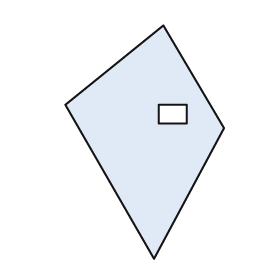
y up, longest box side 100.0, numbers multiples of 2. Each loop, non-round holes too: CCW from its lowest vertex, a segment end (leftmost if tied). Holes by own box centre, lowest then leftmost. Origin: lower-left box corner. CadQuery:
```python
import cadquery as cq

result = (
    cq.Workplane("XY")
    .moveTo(38.0, 0.0)
    .lineTo(68.0, 56.0)
    .lineTo(42.0, 100.0)
    .lineTo(0.0, 66.0)
    .close()
    .moveTo(40.0, 58.0)
    .lineTo(52.0, 58.0)
    .lineTo(52.0, 66.0)
    .lineTo(40.0, 66.0)
    .close()
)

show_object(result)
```